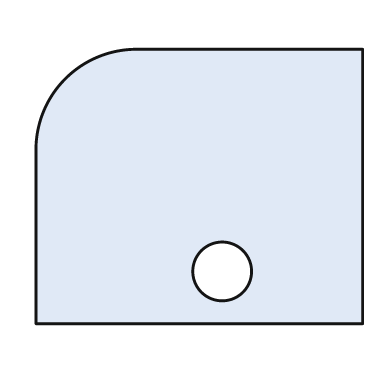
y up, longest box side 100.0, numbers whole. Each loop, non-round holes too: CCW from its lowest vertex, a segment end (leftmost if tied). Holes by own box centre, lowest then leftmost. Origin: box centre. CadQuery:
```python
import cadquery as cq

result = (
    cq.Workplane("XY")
    .moveTo(-50.0, -42.0)
    .lineTo(50.0, -42.0)
    .lineTo(50.0, 42.0)
    .lineTo(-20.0, 42.0)
    .threePointArc((-41.0, 33.0), (-50.0, 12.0))
    .close()
    .moveTo(7.0, -26.0)
    .circle(9.0)
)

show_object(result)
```